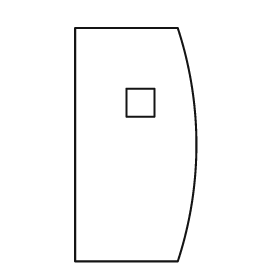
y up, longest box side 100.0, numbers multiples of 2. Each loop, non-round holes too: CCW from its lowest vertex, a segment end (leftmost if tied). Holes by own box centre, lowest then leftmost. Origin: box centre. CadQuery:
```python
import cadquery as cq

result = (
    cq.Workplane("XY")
    .moveTo(-26.0, -50.0)
    .lineTo(18.0, -50.0)
    .threePointArc((26.0, 0.0), (18.0, 50.0))
    .lineTo(-26.0, 50.0)
    .close()
    .moveTo(-4.0, 12.0)
    .lineTo(8.0, 12.0)
    .lineTo(8.0, 24.0)
    .lineTo(-4.0, 24.0)
    .close()
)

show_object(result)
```